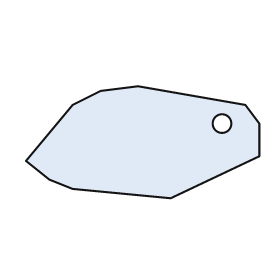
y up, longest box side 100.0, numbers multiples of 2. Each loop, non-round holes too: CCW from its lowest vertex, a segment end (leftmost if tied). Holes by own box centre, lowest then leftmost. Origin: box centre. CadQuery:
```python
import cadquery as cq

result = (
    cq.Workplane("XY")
    .moveTo(12.0, -24.0)
    .lineTo(50.0, -6.0)
    .lineTo(50.0, 8.0)
    .lineTo(44.0, 16.0)
    .lineTo(-2.0, 24.0)
    .lineTo(-18.0, 22.0)
    .lineTo(-30.0, 16.0)
    .lineTo(-50.0, -8.0)
    .lineTo(-40.0, -16.0)
    .lineTo(-30.0, -20.0)
    .close()
    .moveTo(34.0, 8.0)
    .circle(4.0)
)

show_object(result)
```